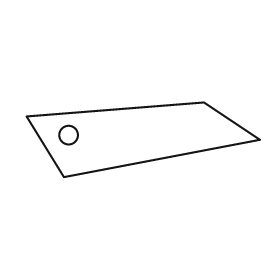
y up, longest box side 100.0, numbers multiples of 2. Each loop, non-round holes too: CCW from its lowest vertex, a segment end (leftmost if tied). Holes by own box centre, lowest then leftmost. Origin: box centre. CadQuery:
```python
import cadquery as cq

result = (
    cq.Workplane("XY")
    .moveTo(-34.0, -16.0)
    .lineTo(50.0, 0.0)
    .lineTo(26.0, 16.0)
    .lineTo(-50.0, 10.0)
    .close()
    .moveTo(-32.0, 2.0)
    .circle(4.0)
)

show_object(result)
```